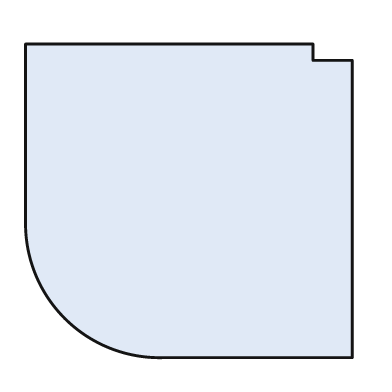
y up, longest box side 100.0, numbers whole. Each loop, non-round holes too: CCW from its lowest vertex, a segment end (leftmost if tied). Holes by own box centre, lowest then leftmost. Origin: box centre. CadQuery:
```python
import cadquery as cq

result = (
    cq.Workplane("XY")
    .moveTo(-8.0, -48.0)
    .lineTo(50.0, -48.0)
    .lineTo(50.0, 43.0)
    .lineTo(38.0, 43.0)
    .lineTo(38.0, 48.0)
    .lineTo(-50.0, 48.0)
    .lineTo(-50.0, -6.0)
    .threePointArc((-38.0, -36.0), (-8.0, -48.0))
    .close()
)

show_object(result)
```